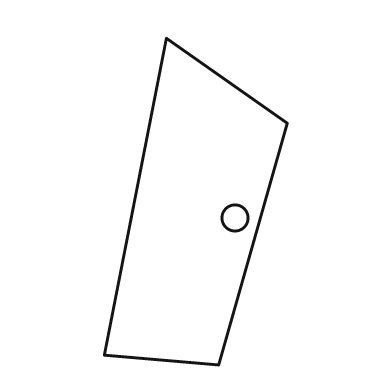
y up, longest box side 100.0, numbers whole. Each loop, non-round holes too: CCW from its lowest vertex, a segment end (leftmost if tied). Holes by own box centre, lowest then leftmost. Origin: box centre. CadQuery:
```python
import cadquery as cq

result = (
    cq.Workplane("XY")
    .moveTo(7.0, -50.0)
    .lineTo(28.0, 24.0)
    .lineTo(-9.0, 50.0)
    .lineTo(-28.0, -47.0)
    .close()
    .moveTo(12.0, -5.0)
    .circle(4.0)
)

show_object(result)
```